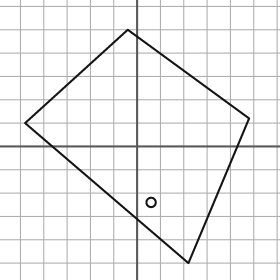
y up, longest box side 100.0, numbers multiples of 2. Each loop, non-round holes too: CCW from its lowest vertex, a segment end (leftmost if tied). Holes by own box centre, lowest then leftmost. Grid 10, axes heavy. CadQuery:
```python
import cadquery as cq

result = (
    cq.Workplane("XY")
    .moveTo(22.0, -50.0)
    .lineTo(48.0, 12.0)
    .lineTo(-4.0, 50.0)
    .lineTo(-48.0, 10.0)
    .close()
    .moveTo(6.0, -24.0)
    .circle(2.0)
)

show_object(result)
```